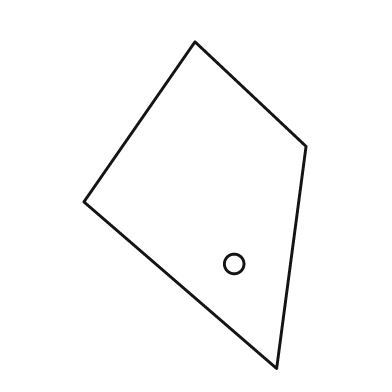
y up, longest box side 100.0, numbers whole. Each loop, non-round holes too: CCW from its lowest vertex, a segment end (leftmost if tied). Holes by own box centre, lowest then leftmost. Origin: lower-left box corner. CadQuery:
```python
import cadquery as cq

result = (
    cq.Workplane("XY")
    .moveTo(59.0, 0.0)
    .lineTo(68.0, 68.0)
    .lineTo(34.0, 100.0)
    .lineTo(0.0, 51.0)
    .close()
    .moveTo(46.0, 32.0)
    .circle(3.0)
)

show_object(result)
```